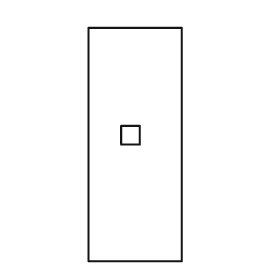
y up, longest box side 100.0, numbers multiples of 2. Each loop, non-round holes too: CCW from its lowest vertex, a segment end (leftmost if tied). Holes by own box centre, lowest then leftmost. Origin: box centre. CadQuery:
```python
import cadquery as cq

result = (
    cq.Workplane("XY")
    .moveTo(-20.0, -50.0)
    .lineTo(20.0, -50.0)
    .lineTo(20.0, 50.0)
    .lineTo(-20.0, 50.0)
    .close()
    .moveTo(-6.0, 0.0)
    .lineTo(2.0, 0.0)
    .lineTo(2.0, 8.0)
    .lineTo(-6.0, 8.0)
    .close()
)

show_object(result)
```